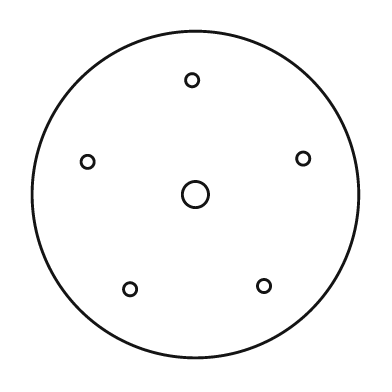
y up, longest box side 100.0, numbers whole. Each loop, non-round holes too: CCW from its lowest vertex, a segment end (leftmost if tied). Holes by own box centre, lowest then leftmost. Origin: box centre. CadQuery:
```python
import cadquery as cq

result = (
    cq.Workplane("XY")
    .moveTo(0.0, 0.0)
    .circle(50.0)
    .moveTo(-20.0, -29.0)
    .circle(2.0)
    .moveTo(21.0, -28.0)
    .circle(2.0)
    .moveTo(0.0, 0.0)
    .circle(4.0)
    .moveTo(-33.0, 10.0)
    .circle(2.0)
    .moveTo(33.0, 11.0)
    .circle(2.0)
    .moveTo(-1.0, 35.0)
    .circle(2.0)
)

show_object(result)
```